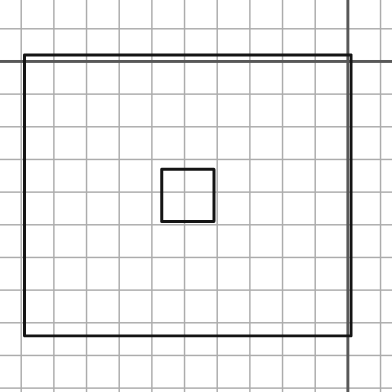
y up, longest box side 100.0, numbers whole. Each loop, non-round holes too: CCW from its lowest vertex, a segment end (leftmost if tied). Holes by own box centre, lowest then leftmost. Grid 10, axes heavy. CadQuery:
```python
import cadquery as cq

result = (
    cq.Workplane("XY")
    .moveTo(-99.0, -84.0)
    .lineTo(1.0, -84.0)
    .lineTo(1.0, 2.0)
    .lineTo(-99.0, 2.0)
    .close()
    .moveTo(-57.0, -49.0)
    .lineTo(-41.0, -49.0)
    .lineTo(-41.0, -33.0)
    .lineTo(-57.0, -33.0)
    .close()
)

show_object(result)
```